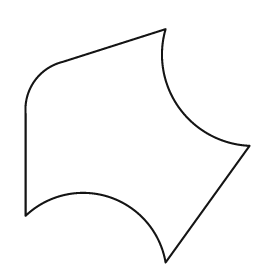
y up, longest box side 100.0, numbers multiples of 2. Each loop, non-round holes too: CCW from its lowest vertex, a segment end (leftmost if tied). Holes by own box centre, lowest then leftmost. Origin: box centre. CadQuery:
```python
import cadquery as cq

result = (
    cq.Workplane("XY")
    .moveTo(12.0, -50.0)
    .lineTo(48.0, 0.0)
    .threePointArc((18.0, 16.0), (12.0, 50.0))
    .lineTo(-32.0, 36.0)
    .threePointArc((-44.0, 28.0), (-48.0, 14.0))
    .lineTo(-48.0, -30.0)
    .threePointArc((-12.0, -22.0), (12.0, -50.0))
    .close()
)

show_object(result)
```